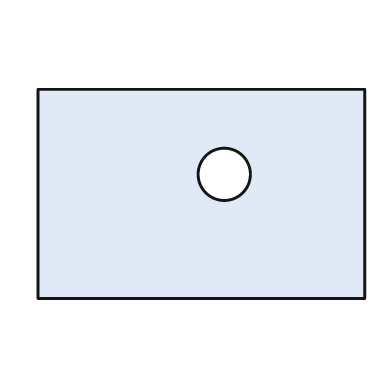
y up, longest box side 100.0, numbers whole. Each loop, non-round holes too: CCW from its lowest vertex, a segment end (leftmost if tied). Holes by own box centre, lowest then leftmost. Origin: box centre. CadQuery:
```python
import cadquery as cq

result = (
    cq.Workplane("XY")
    .moveTo(-50.0, -32.0)
    .lineTo(50.0, -32.0)
    .lineTo(50.0, 32.0)
    .lineTo(-50.0, 32.0)
    .close()
    .moveTo(7.0, 6.0)
    .circle(8.0)
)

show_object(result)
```